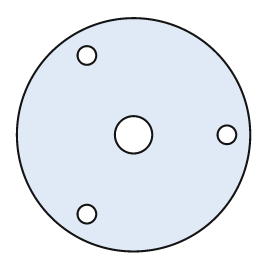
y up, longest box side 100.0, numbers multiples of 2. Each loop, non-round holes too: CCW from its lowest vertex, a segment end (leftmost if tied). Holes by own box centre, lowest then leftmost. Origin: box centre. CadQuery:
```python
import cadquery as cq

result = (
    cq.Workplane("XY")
    .moveTo(0.0, 0.0)
    .circle(50.0)
    .moveTo(-20.0, -34.0)
    .circle(4.0)
    .moveTo(0.0, 0.0)
    .circle(8.0)
    .moveTo(40.0, 0.0)
    .circle(4.0)
    .moveTo(-20.0, 34.0)
    .circle(4.0)
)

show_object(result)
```